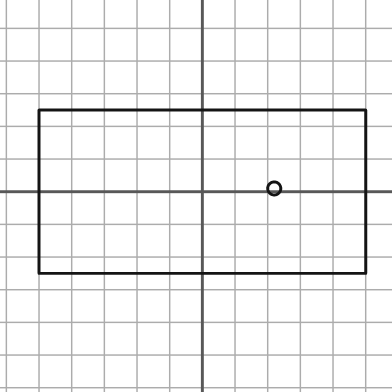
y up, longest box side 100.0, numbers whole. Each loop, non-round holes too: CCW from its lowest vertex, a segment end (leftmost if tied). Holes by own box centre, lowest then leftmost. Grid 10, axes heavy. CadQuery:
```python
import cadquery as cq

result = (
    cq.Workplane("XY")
    .moveTo(-50.0, -25.0)
    .lineTo(50.0, -25.0)
    .lineTo(50.0, 25.0)
    .lineTo(-50.0, 25.0)
    .close()
    .moveTo(22.0, 1.0)
    .circle(2.0)
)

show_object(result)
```